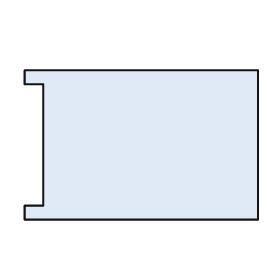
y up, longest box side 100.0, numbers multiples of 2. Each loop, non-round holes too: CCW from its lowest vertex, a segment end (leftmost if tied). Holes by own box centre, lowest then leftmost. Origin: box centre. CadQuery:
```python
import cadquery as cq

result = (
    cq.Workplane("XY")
    .moveTo(-50.0, -32.0)
    .lineTo(50.0, -32.0)
    .lineTo(50.0, 32.0)
    .lineTo(-50.0, 32.0)
    .lineTo(-50.0, 26.0)
    .lineTo(-42.0, 26.0)
    .lineTo(-42.0, -26.0)
    .lineTo(-50.0, -26.0)
    .close()
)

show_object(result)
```